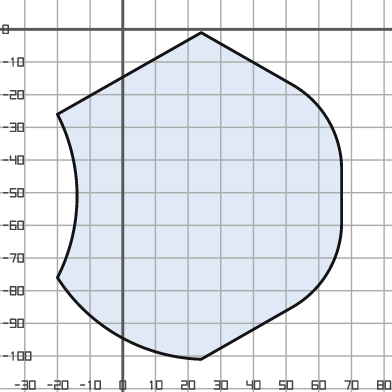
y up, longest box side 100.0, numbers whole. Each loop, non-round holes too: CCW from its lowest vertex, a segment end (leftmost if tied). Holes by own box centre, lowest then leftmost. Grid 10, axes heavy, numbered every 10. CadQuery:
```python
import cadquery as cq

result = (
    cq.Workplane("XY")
    .moveTo(24.0, -101.0)
    .lineTo(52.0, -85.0)
    .threePointArc((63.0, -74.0), (67.0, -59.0))
    .lineTo(67.0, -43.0)
    .threePointArc((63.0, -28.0), (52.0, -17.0))
    .lineTo(24.0, -1.0)
    .lineTo(-20.0, -26.0)
    .threePointArc((-14.0, -51.0), (-20.0, -76.0))
    .threePointArc((-1.0, -94.0), (24.0, -101.0))
    .close()
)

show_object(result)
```